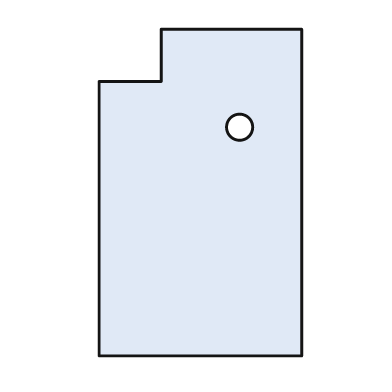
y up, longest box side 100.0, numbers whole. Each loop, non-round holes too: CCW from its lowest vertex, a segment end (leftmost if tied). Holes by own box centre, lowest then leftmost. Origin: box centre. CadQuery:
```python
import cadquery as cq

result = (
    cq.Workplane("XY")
    .moveTo(-31.0, -50.0)
    .lineTo(31.0, -50.0)
    .lineTo(31.0, 50.0)
    .lineTo(-12.0, 50.0)
    .lineTo(-12.0, 34.0)
    .lineTo(-31.0, 34.0)
    .close()
    .moveTo(12.0, 20.0)
    .circle(4.0)
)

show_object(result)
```